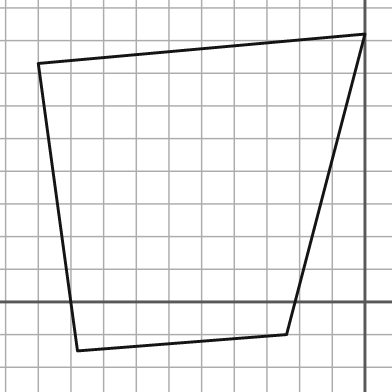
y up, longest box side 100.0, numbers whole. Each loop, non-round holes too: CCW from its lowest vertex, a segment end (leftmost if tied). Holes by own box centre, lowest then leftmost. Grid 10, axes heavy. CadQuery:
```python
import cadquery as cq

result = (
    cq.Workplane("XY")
    .moveTo(-88.0, -15.0)
    .lineTo(-24.0, -10.0)
    .lineTo(0.0, 82.0)
    .lineTo(-100.0, 73.0)
    .close()
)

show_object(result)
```